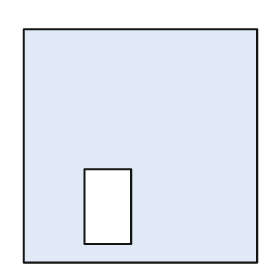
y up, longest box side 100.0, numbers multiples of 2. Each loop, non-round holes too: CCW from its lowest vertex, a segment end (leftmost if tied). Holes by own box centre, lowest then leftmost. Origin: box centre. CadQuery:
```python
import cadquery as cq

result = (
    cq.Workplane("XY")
    .moveTo(-50.0, -50.0)
    .lineTo(50.0, -50.0)
    .lineTo(50.0, 50.0)
    .lineTo(-50.0, 50.0)
    .close()
    .moveTo(-24.0, -42.0)
    .lineTo(-4.0, -42.0)
    .lineTo(-4.0, -10.0)
    .lineTo(-24.0, -10.0)
    .close()
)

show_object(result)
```